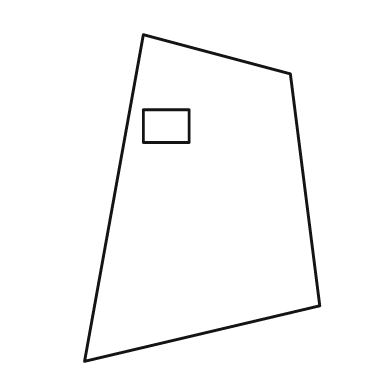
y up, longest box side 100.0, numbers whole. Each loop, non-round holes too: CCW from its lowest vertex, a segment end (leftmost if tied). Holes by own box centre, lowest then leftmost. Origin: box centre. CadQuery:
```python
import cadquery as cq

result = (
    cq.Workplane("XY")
    .moveTo(-36.0, -50.0)
    .lineTo(36.0, -33.0)
    .lineTo(27.0, 38.0)
    .lineTo(-18.0, 50.0)
    .close()
    .moveTo(-18.0, 17.0)
    .lineTo(-4.0, 17.0)
    .lineTo(-4.0, 27.0)
    .lineTo(-18.0, 27.0)
    .close()
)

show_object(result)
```